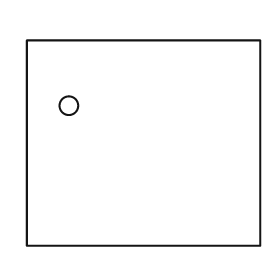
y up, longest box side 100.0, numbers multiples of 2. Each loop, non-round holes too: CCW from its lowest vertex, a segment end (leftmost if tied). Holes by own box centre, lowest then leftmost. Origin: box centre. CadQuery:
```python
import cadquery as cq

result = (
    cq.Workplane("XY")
    .moveTo(-50.0, -44.0)
    .lineTo(50.0, -44.0)
    .lineTo(50.0, 44.0)
    .lineTo(-50.0, 44.0)
    .close()
    .moveTo(-32.0, 16.0)
    .circle(4.0)
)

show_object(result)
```